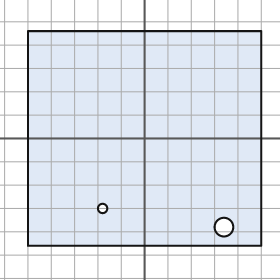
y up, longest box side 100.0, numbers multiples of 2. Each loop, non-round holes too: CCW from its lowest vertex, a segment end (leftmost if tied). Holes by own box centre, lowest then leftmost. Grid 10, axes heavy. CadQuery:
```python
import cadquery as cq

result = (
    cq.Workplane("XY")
    .moveTo(-50.0, -46.0)
    .lineTo(50.0, -46.0)
    .lineTo(50.0, 46.0)
    .lineTo(-50.0, 46.0)
    .close()
    .moveTo(34.0, -38.0)
    .circle(4.0)
    .moveTo(-18.0, -30.0)
    .circle(2.0)
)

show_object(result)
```